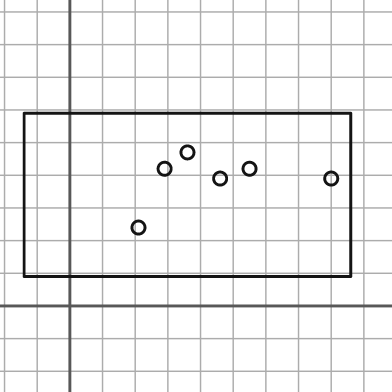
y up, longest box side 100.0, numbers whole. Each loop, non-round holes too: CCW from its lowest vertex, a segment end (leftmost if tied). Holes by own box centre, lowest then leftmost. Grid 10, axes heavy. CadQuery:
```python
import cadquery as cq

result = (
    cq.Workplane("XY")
    .moveTo(-14.0, 9.0)
    .lineTo(86.0, 9.0)
    .lineTo(86.0, 59.0)
    .lineTo(-14.0, 59.0)
    .close()
    .moveTo(21.0, 24.0)
    .circle(2.0)
    .moveTo(46.0, 39.0)
    .circle(2.0)
    .moveTo(80.0, 39.0)
    .circle(2.0)
    .moveTo(29.0, 42.0)
    .circle(2.0)
    .moveTo(55.0, 42.0)
    .circle(2.0)
    .moveTo(36.0, 47.0)
    .circle(2.0)
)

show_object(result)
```